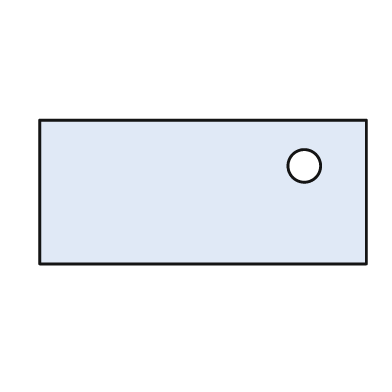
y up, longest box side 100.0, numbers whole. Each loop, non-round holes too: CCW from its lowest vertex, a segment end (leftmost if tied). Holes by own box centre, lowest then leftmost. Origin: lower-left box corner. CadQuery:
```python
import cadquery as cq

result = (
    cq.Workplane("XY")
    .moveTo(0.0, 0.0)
    .lineTo(100.0, 0.0)
    .lineTo(100.0, 44.0)
    .lineTo(0.0, 44.0)
    .close()
    .moveTo(81.0, 30.0)
    .circle(5.0)
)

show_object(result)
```